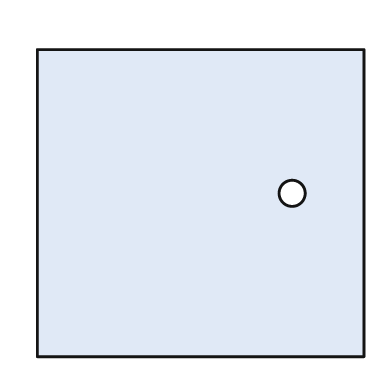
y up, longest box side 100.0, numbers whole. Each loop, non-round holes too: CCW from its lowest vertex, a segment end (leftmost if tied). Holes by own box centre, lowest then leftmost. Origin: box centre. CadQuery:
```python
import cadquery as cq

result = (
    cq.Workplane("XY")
    .moveTo(-50.0, -47.0)
    .lineTo(50.0, -47.0)
    .lineTo(50.0, 47.0)
    .lineTo(-50.0, 47.0)
    .close()
    .moveTo(28.0, 3.0)
    .circle(4.0)
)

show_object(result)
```